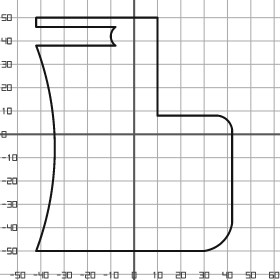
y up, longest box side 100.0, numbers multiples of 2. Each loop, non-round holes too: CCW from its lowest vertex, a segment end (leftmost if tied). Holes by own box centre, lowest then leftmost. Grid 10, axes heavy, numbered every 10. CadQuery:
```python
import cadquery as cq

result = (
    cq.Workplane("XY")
    .moveTo(-42.0, -50.0)
    .lineTo(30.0, -50.0)
    .threePointArc((38.0, -46.0), (42.0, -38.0))
    .lineTo(42.0, 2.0)
    .threePointArc((40.0, 6.0), (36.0, 8.0))
    .lineTo(10.0, 8.0)
    .lineTo(10.0, 50.0)
    .lineTo(-42.0, 50.0)
    .lineTo(-42.0, 46.0)
    .lineTo(-8.0, 46.0)
    .threePointArc((-10.0, 42.0), (-8.0, 38.0))
    .lineTo(-42.0, 38.0)
    .threePointArc((-34.0, -6.0), (-42.0, -50.0))
    .close()
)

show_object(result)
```